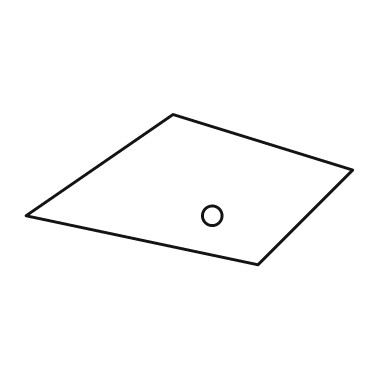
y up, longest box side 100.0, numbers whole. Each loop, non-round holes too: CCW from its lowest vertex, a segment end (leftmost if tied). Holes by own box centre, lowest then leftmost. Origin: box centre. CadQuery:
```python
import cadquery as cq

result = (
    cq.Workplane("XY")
    .moveTo(21.0, -23.0)
    .lineTo(50.0, 6.0)
    .lineTo(-5.0, 23.0)
    .lineTo(-50.0, -8.0)
    .close()
    .moveTo(7.0, -8.0)
    .circle(3.0)
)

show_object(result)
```